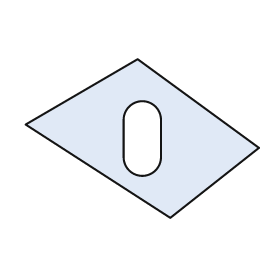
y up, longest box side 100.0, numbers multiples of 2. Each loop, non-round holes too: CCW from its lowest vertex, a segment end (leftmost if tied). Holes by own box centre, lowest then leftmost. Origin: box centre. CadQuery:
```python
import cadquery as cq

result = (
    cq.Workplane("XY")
    .moveTo(12.0, -34.0)
    .lineTo(50.0, -4.0)
    .lineTo(-2.0, 34.0)
    .lineTo(-50.0, 6.0)
    .close()
    .moveTo(-8.0, -8.0)
    .threePointArc((0.0, -16.0), (8.0, -8.0))
    .lineTo(8.0, 8.0)
    .threePointArc((0.0, 16.0), (-8.0, 8.0))
    .close()
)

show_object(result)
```